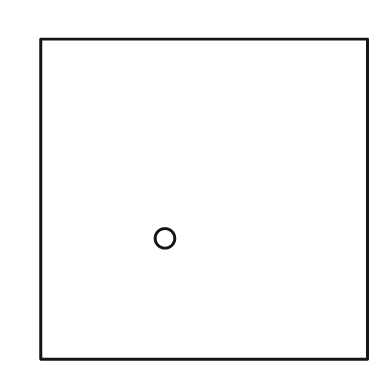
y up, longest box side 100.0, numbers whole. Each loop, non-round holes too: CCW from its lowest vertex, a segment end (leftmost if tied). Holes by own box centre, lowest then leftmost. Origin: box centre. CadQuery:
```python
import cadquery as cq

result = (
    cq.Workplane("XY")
    .moveTo(-50.0, -49.0)
    .lineTo(50.0, -49.0)
    .lineTo(50.0, 49.0)
    .lineTo(-50.0, 49.0)
    .close()
    .moveTo(-12.0, -12.0)
    .circle(3.0)
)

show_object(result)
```